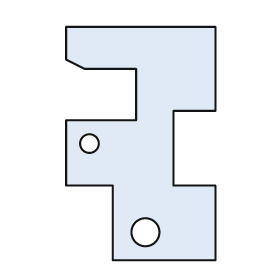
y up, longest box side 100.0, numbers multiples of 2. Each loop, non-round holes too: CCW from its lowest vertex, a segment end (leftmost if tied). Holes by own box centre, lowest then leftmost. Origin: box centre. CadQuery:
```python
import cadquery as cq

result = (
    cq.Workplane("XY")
    .moveTo(-12.0, -50.0)
    .lineTo(32.0, -50.0)
    .lineTo(32.0, -18.0)
    .lineTo(14.0, -18.0)
    .lineTo(14.0, 14.0)
    .lineTo(32.0, 14.0)
    .lineTo(32.0, 50.0)
    .lineTo(-32.0, 50.0)
    .lineTo(-32.0, 36.0)
    .lineTo(-24.0, 32.0)
    .lineTo(-2.0, 32.0)
    .lineTo(-2.0, 10.0)
    .lineTo(-32.0, 10.0)
    .lineTo(-32.0, -18.0)
    .lineTo(-12.0, -18.0)
    .close()
    .moveTo(2.0, -38.0)
    .circle(6.0)
    .moveTo(-22.0, 0.0)
    .circle(4.0)
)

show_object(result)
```